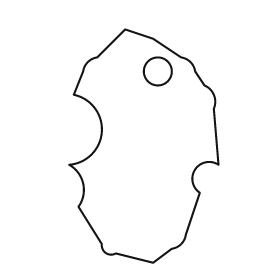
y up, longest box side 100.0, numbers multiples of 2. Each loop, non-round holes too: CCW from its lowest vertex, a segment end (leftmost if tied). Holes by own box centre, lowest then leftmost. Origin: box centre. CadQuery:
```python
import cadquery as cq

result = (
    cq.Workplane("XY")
    .moveTo(4.0, -50.0)
    .lineTo(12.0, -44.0)
    .threePointArc((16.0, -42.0), (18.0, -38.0))
    .lineTo(24.0, -20.0)
    .threePointArc((22.0, -10.0), (32.0, -8.0))
    .lineTo(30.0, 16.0)
    .threePointArc((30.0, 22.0), (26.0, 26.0))
    .lineTo(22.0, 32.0)
    .threePointArc((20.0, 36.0), (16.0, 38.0))
    .lineTo(4.0, 46.0)
    .lineTo(-8.0, 50.0)
    .lineTo(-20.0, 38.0)
    .threePointArc((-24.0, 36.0), (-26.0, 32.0))
    .lineTo(-30.0, 22.0)
    .threePointArc((-18.0, 6.0), (-32.0, -8.0))
    .threePointArc((-26.0, -16.0), (-28.0, -26.0))
    .lineTo(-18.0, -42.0)
    .threePointArc((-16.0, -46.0), (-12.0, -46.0))
    .close()
    .moveTo(6.0, 32.0)
    .circle(6.0)
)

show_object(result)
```